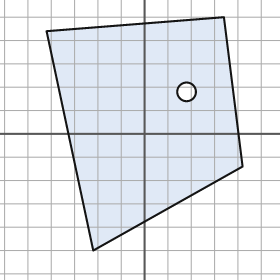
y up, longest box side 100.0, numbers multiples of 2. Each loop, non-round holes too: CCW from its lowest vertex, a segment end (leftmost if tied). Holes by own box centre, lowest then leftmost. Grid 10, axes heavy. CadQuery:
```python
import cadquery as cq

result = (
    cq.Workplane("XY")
    .moveTo(-22.0, -50.0)
    .lineTo(42.0, -14.0)
    .lineTo(34.0, 50.0)
    .lineTo(-42.0, 44.0)
    .close()
    .moveTo(18.0, 18.0)
    .circle(4.0)
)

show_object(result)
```